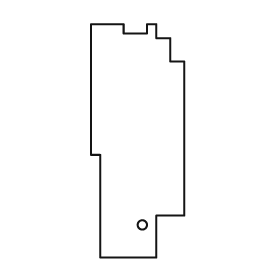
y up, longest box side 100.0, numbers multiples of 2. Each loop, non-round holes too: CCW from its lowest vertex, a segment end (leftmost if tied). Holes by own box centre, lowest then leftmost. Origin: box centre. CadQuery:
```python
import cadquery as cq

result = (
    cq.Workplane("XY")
    .moveTo(-16.0, -50.0)
    .lineTo(8.0, -50.0)
    .lineTo(8.0, -32.0)
    .lineTo(20.0, -32.0)
    .lineTo(20.0, 34.0)
    .lineTo(14.0, 34.0)
    .lineTo(14.0, 44.0)
    .lineTo(8.0, 44.0)
    .lineTo(8.0, 50.0)
    .lineTo(4.0, 50.0)
    .lineTo(4.0, 46.0)
    .lineTo(-6.0, 46.0)
    .lineTo(-6.0, 50.0)
    .lineTo(-20.0, 50.0)
    .lineTo(-20.0, -6.0)
    .lineTo(-16.0, -6.0)
    .close()
    .moveTo(2.0, -36.0)
    .circle(2.0)
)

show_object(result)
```